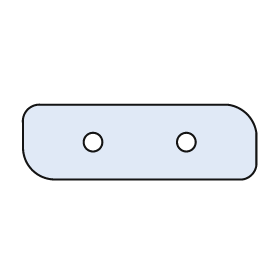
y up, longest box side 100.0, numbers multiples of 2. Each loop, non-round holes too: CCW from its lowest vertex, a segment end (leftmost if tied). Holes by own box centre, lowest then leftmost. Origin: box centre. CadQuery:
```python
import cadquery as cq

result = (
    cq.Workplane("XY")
    .moveTo(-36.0, -16.0)
    .lineTo(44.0, -16.0)
    .threePointArc((48.0, -14.0), (50.0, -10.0))
    .lineTo(50.0, 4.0)
    .threePointArc((46.0, 12.0), (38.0, 16.0))
    .lineTo(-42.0, 16.0)
    .threePointArc((-48.0, 14.0), (-50.0, 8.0))
    .lineTo(-50.0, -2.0)
    .threePointArc((-46.0, -12.0), (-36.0, -16.0))
    .close()
    .moveTo(-20.0, 0.0)
    .circle(4.0)
    .moveTo(20.0, 0.0)
    .circle(4.0)
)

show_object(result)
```